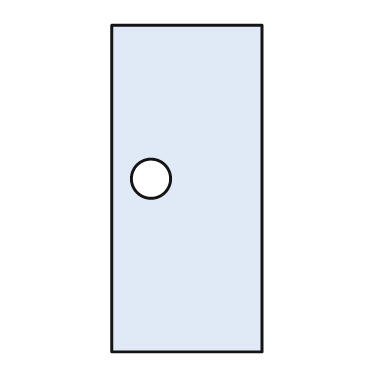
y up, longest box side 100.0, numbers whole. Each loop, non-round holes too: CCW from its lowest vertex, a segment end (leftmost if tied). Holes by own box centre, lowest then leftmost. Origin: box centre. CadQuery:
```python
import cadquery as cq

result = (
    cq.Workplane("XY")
    .moveTo(-23.0, -50.0)
    .lineTo(23.0, -50.0)
    .lineTo(23.0, 50.0)
    .lineTo(-23.0, 50.0)
    .close()
    .moveTo(-11.0, 3.0)
    .circle(6.0)
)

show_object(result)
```